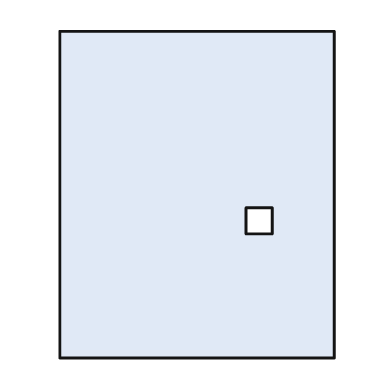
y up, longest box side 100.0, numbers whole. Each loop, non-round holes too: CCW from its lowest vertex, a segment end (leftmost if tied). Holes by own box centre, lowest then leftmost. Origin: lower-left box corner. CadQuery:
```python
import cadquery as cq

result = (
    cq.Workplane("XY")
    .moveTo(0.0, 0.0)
    .lineTo(84.0, 0.0)
    .lineTo(84.0, 100.0)
    .lineTo(0.0, 100.0)
    .close()
    .moveTo(57.0, 38.0)
    .lineTo(65.0, 38.0)
    .lineTo(65.0, 46.0)
    .lineTo(57.0, 46.0)
    .close()
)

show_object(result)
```